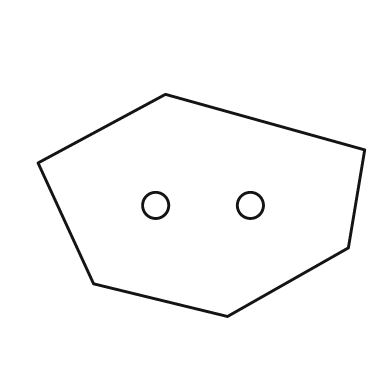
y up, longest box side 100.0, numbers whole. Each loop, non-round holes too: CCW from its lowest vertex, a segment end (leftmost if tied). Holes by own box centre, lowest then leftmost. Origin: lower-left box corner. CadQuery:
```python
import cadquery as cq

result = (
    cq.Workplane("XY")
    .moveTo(58.0, 0.0)
    .lineTo(95.0, 21.0)
    .lineTo(100.0, 51.0)
    .lineTo(39.0, 68.0)
    .lineTo(0.0, 47.0)
    .lineTo(17.0, 10.0)
    .close()
    .moveTo(36.0, 34.0)
    .circle(4.0)
    .moveTo(65.0, 34.0)
    .circle(4.0)
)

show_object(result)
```